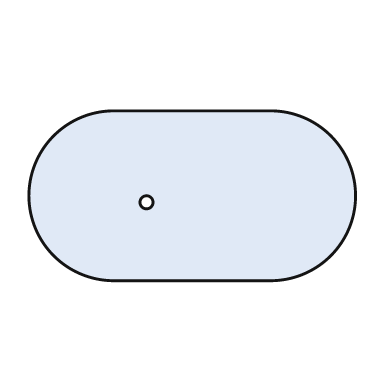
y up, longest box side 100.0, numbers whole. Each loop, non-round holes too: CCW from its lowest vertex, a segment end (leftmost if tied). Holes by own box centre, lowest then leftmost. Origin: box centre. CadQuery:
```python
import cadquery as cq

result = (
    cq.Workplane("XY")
    .moveTo(-24.0, -26.0)
    .lineTo(24.0, -26.0)
    .threePointArc((50.0, 0.0), (24.0, 26.0))
    .lineTo(-24.0, 26.0)
    .threePointArc((-50.0, 0.0), (-24.0, -26.0))
    .close()
    .moveTo(-14.0, -2.0)
    .circle(2.0)
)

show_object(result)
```